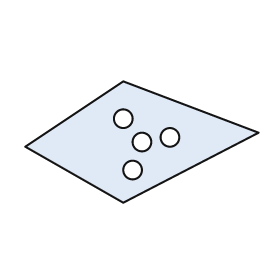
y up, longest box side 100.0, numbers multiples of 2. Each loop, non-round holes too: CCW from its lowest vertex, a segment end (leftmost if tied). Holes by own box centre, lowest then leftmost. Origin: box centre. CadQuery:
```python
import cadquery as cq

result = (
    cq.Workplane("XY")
    .moveTo(-8.0, -26.0)
    .lineTo(50.0, 4.0)
    .lineTo(-8.0, 26.0)
    .lineTo(-50.0, -2.0)
    .close()
    .moveTo(-4.0, -12.0)
    .circle(4.0)
    .moveTo(0.0, 0.0)
    .circle(4.0)
    .moveTo(12.0, 2.0)
    .circle(4.0)
    .moveTo(-8.0, 10.0)
    .circle(4.0)
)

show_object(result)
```